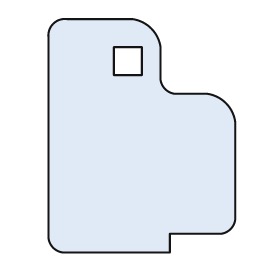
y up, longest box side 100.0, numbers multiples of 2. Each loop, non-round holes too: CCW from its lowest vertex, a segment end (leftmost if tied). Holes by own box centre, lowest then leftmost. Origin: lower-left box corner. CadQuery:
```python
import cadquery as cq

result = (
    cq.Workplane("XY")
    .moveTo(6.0, 0.0)
    .lineTo(52.0, 0.0)
    .lineTo(52.0, 8.0)
    .lineTo(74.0, 8.0)
    .threePointArc((78.0, 10.0), (80.0, 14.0))
    .lineTo(80.0, 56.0)
    .threePointArc((76.0, 64.0), (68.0, 68.0))
    .lineTo(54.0, 68.0)
    .threePointArc((50.0, 70.0), (48.0, 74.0))
    .lineTo(48.0, 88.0)
    .threePointArc((44.0, 96.0), (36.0, 100.0))
    .lineTo(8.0, 100.0)
    .threePointArc((2.0, 98.0), (0.0, 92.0))
    .lineTo(0.0, 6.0)
    .threePointArc((2.0, 2.0), (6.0, 0.0))
    .close()
    .moveTo(28.0, 76.0)
    .lineTo(40.0, 76.0)
    .lineTo(40.0, 88.0)
    .lineTo(28.0, 88.0)
    .close()
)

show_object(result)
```